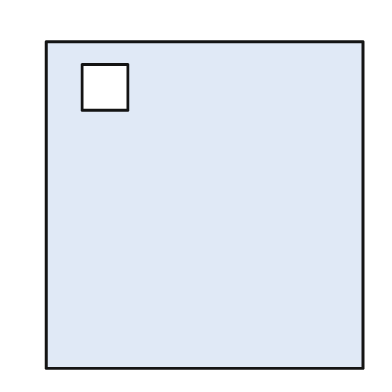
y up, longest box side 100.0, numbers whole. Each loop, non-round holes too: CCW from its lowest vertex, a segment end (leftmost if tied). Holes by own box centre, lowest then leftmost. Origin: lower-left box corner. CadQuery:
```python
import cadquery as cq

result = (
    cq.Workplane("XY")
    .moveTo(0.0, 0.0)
    .lineTo(97.0, 0.0)
    .lineTo(97.0, 100.0)
    .lineTo(0.0, 100.0)
    .close()
    .moveTo(11.0, 79.0)
    .lineTo(25.0, 79.0)
    .lineTo(25.0, 93.0)
    .lineTo(11.0, 93.0)
    .close()
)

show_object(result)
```